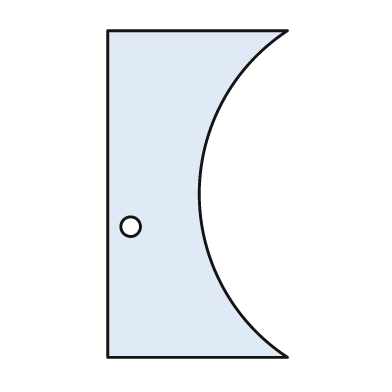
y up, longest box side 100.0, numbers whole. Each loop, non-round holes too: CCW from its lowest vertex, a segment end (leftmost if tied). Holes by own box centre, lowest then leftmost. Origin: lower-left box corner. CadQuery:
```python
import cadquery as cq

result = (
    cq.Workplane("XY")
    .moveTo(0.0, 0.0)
    .lineTo(55.0, 0.0)
    .threePointArc((28.0, 50.0), (55.0, 100.0))
    .lineTo(0.0, 100.0)
    .close()
    .moveTo(7.0, 40.0)
    .circle(3.0)
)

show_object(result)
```